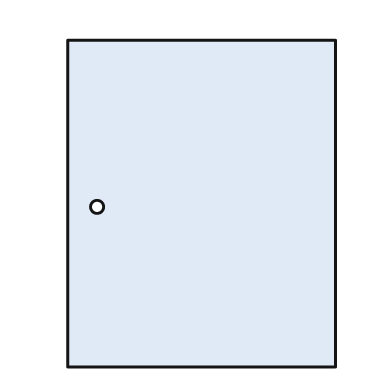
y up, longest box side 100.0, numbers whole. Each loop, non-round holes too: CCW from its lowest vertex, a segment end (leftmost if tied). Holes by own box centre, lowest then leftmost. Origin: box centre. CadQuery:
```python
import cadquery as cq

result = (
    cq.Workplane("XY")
    .moveTo(-41.0, -50.0)
    .lineTo(41.0, -50.0)
    .lineTo(41.0, 50.0)
    .lineTo(-41.0, 50.0)
    .close()
    .moveTo(-32.0, -1.0)
    .circle(2.0)
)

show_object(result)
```